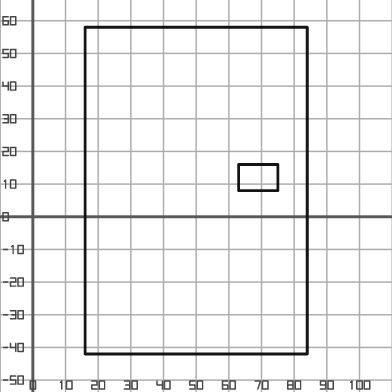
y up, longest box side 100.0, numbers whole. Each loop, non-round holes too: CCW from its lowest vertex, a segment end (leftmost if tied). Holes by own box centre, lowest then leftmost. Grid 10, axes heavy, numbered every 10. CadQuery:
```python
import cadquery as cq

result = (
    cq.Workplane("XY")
    .moveTo(16.0, -42.0)
    .lineTo(84.0, -42.0)
    .lineTo(84.0, 58.0)
    .lineTo(16.0, 58.0)
    .close()
    .moveTo(63.0, 8.0)
    .lineTo(75.0, 8.0)
    .lineTo(75.0, 16.0)
    .lineTo(63.0, 16.0)
    .close()
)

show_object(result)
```